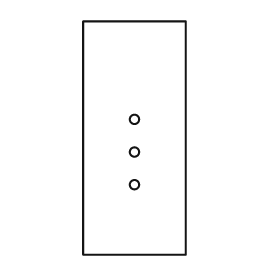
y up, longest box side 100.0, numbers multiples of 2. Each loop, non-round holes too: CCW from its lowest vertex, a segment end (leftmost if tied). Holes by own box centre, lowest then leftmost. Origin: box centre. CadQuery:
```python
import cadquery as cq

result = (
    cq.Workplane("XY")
    .moveTo(-22.0, -50.0)
    .lineTo(22.0, -50.0)
    .lineTo(22.0, 50.0)
    .lineTo(-22.0, 50.0)
    .close()
    .moveTo(0.0, -20.0)
    .circle(2.0)
    .moveTo(0.0, -6.0)
    .circle(2.0)
    .moveTo(0.0, 8.0)
    .circle(2.0)
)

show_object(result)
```